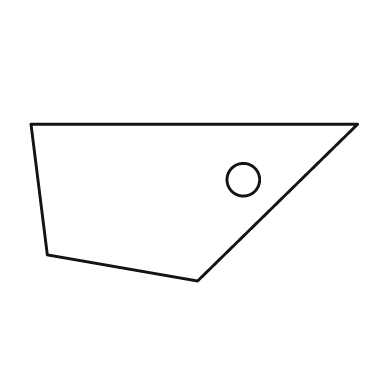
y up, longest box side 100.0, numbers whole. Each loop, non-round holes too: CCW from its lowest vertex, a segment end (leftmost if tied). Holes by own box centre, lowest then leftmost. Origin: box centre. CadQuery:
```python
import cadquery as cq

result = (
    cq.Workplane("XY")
    .moveTo(1.0, -24.0)
    .lineTo(50.0, 24.0)
    .lineTo(-50.0, 24.0)
    .lineTo(-45.0, -16.0)
    .close()
    .moveTo(15.0, 7.0)
    .circle(5.0)
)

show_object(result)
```